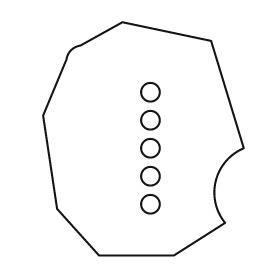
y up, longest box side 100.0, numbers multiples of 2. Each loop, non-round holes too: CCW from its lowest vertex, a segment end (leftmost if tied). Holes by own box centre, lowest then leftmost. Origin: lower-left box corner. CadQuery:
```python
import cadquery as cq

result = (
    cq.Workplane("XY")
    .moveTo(24.0, 0.0)
    .lineTo(56.0, 0.0)
    .lineTo(78.0, 14.0)
    .threePointArc((74.0, 32.0), (86.0, 46.0))
    .lineTo(72.0, 92.0)
    .lineTo(34.0, 100.0)
    .lineTo(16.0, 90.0)
    .threePointArc((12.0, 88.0), (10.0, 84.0))
    .lineTo(0.0, 60.0)
    .lineTo(6.0, 20.0)
    .close()
    .moveTo(46.0, 22.0)
    .circle(4.0)
    .moveTo(46.0, 34.0)
    .circle(4.0)
    .moveTo(46.0, 46.0)
    .circle(4.0)
    .moveTo(46.0, 58.0)
    .circle(4.0)
    .moveTo(46.0, 70.0)
    .circle(4.0)
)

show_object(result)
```